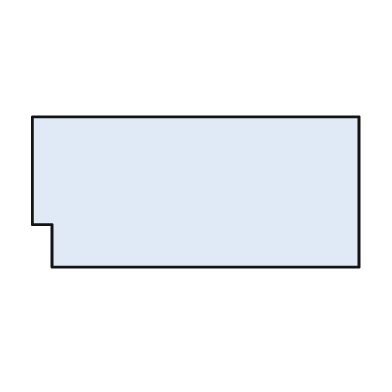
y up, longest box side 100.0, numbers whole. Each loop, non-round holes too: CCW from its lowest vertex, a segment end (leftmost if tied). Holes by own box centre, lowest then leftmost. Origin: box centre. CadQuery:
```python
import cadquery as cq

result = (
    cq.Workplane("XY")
    .moveTo(-44.0, -23.0)
    .lineTo(50.0, -23.0)
    .lineTo(50.0, 23.0)
    .lineTo(-50.0, 23.0)
    .lineTo(-50.0, -10.0)
    .lineTo(-44.0, -10.0)
    .close()
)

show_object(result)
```